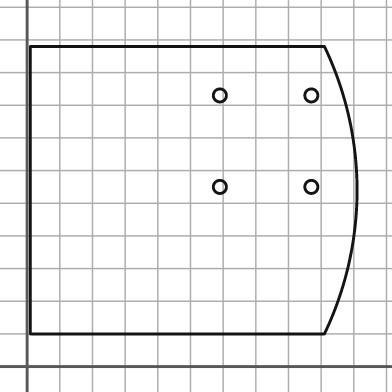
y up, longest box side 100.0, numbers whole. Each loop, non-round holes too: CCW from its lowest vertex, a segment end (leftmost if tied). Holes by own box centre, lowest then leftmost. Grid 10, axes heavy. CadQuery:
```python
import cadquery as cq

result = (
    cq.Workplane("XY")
    .moveTo(1.0, 10.0)
    .lineTo(91.0, 10.0)
    .threePointArc((101.0, 54.0), (91.0, 98.0))
    .lineTo(1.0, 98.0)
    .close()
    .moveTo(59.0, 55.0)
    .circle(2.0)
    .moveTo(87.0, 55.0)
    .circle(2.0)
    .moveTo(59.0, 83.0)
    .circle(2.0)
    .moveTo(87.0, 83.0)
    .circle(2.0)
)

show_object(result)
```